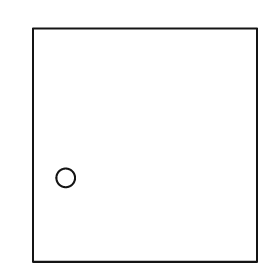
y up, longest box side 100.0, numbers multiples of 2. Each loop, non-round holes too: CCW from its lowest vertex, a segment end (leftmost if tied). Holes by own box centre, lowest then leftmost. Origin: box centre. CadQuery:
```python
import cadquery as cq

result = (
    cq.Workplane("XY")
    .moveTo(-48.0, -50.0)
    .lineTo(48.0, -50.0)
    .lineTo(48.0, 50.0)
    .lineTo(-48.0, 50.0)
    .close()
    .moveTo(-34.0, -14.0)
    .circle(4.0)
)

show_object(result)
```